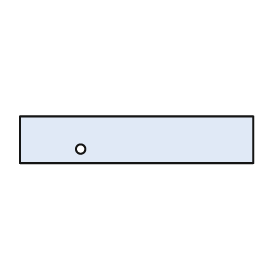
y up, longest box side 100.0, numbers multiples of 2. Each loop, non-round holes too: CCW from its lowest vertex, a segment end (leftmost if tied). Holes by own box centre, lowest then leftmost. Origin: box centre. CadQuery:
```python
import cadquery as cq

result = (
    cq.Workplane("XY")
    .moveTo(-50.0, -10.0)
    .lineTo(50.0, -10.0)
    .lineTo(50.0, 10.0)
    .lineTo(-50.0, 10.0)
    .close()
    .moveTo(-24.0, -4.0)
    .circle(2.0)
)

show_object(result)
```